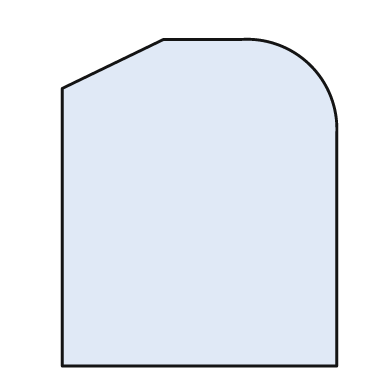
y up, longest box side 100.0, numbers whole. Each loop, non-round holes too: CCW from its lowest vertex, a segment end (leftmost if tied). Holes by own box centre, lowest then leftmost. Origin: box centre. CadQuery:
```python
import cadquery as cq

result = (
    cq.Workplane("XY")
    .moveTo(-42.0, -50.0)
    .lineTo(42.0, -50.0)
    .lineTo(42.0, 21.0)
    .threePointArc((34.0, 42.0), (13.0, 50.0))
    .lineTo(-11.0, 50.0)
    .lineTo(-42.0, 35.0)
    .close()
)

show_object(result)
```